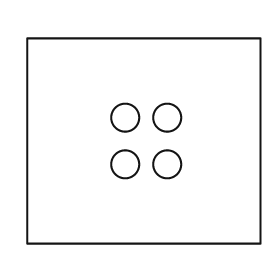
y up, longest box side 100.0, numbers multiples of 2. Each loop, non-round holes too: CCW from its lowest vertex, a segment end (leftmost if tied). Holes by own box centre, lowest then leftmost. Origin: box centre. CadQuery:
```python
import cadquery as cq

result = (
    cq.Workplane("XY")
    .moveTo(-50.0, -44.0)
    .lineTo(50.0, -44.0)
    .lineTo(50.0, 44.0)
    .lineTo(-50.0, 44.0)
    .close()
    .moveTo(-8.0, -10.0)
    .circle(6.0)
    .moveTo(10.0, -10.0)
    .circle(6.0)
    .moveTo(-8.0, 10.0)
    .circle(6.0)
    .moveTo(10.0, 10.0)
    .circle(6.0)
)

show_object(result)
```